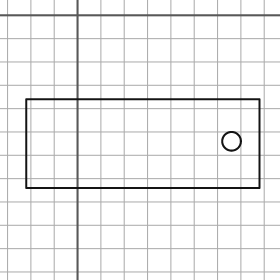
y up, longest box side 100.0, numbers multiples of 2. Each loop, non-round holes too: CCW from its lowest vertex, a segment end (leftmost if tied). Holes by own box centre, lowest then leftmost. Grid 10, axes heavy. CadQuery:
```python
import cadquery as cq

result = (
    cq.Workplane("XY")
    .moveTo(-22.0, -74.0)
    .lineTo(78.0, -74.0)
    .lineTo(78.0, -36.0)
    .lineTo(-22.0, -36.0)
    .close()
    .moveTo(66.0, -54.0)
    .circle(4.0)
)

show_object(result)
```